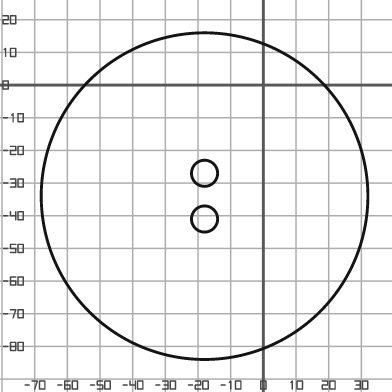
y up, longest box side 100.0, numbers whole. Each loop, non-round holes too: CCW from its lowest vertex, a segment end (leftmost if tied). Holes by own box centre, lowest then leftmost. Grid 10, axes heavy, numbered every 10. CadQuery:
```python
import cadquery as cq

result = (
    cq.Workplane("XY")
    .moveTo(-18.0, -34.0)
    .circle(50.0)
    .moveTo(-18.0, -41.0)
    .circle(4.0)
    .moveTo(-18.0, -27.0)
    .circle(4.0)
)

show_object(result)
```